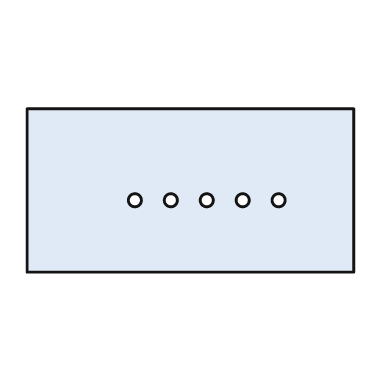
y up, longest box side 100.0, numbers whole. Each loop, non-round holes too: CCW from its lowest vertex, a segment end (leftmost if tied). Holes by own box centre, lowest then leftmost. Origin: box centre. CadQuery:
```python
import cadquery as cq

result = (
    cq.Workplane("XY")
    .moveTo(-50.0, -25.0)
    .lineTo(50.0, -25.0)
    .lineTo(50.0, 25.0)
    .lineTo(-50.0, 25.0)
    .close()
    .moveTo(-17.0, -3.0)
    .circle(2.0)
    .moveTo(-6.0, -3.0)
    .circle(2.0)
    .moveTo(5.0, -3.0)
    .circle(2.0)
    .moveTo(16.0, -3.0)
    .circle(2.0)
    .moveTo(27.0, -3.0)
    .circle(2.0)
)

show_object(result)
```